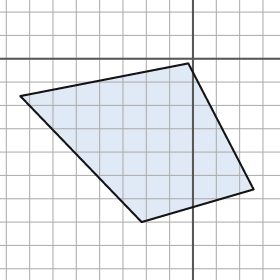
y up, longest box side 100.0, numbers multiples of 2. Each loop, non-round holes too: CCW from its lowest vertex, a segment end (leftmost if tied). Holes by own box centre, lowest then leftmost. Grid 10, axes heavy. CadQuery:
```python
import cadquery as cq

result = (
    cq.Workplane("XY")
    .moveTo(-22.0, -70.0)
    .lineTo(26.0, -56.0)
    .lineTo(-2.0, -2.0)
    .lineTo(-74.0, -16.0)
    .close()
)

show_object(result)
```